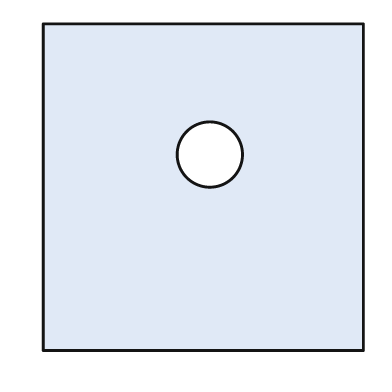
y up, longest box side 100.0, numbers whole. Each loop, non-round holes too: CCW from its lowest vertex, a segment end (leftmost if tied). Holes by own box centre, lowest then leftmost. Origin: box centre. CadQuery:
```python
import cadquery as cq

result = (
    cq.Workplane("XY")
    .moveTo(-49.0, -50.0)
    .lineTo(49.0, -50.0)
    .lineTo(49.0, 50.0)
    .lineTo(-49.0, 50.0)
    .close()
    .moveTo(2.0, 10.0)
    .circle(10.0)
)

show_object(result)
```